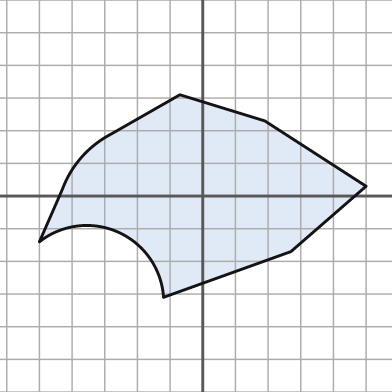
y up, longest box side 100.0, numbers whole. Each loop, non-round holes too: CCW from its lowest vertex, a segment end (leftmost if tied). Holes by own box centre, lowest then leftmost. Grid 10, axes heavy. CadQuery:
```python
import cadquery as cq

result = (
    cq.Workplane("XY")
    .moveTo(-12.0, -31.0)
    .lineTo(27.0, -17.0)
    .lineTo(50.0, 3.0)
    .lineTo(19.0, 23.0)
    .lineTo(-7.0, 31.0)
    .lineTo(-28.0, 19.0)
    .threePointArc((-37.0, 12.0), (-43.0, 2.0))
    .lineTo(-50.0, -14.0)
    .threePointArc((-26.0, -11.0), (-12.0, -31.0))
    .close()
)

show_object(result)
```